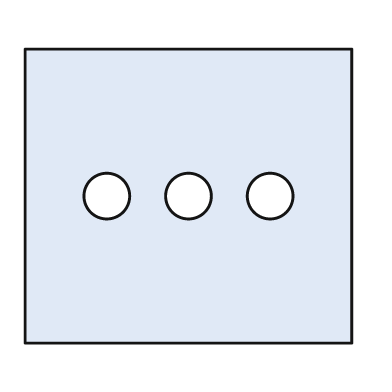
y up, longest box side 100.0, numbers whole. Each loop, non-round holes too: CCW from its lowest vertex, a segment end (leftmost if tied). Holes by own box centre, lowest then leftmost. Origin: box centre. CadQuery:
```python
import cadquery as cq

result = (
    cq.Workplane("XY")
    .moveTo(-50.0, -45.0)
    .lineTo(50.0, -45.0)
    .lineTo(50.0, 45.0)
    .lineTo(-50.0, 45.0)
    .close()
    .moveTo(-25.0, 0.0)
    .circle(7.0)
    .moveTo(0.0, 0.0)
    .circle(7.0)
    .moveTo(25.0, 0.0)
    .circle(7.0)
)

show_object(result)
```